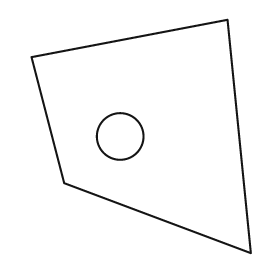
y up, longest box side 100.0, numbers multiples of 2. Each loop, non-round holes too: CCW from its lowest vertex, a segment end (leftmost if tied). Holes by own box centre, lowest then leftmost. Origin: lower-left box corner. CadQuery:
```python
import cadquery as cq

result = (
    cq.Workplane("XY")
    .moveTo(94.0, 0.0)
    .lineTo(84.0, 100.0)
    .lineTo(0.0, 84.0)
    .lineTo(14.0, 30.0)
    .close()
    .moveTo(38.0, 50.0)
    .circle(10.0)
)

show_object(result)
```